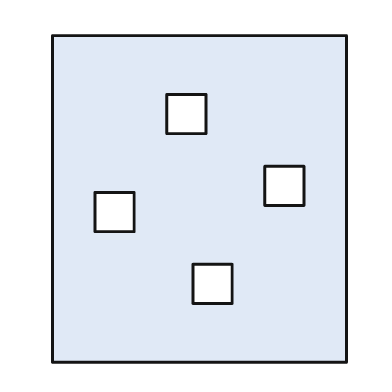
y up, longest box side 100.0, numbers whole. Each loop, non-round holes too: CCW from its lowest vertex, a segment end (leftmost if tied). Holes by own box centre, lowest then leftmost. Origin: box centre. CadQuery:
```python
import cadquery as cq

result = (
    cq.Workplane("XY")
    .moveTo(-45.0, -50.0)
    .lineTo(45.0, -50.0)
    .lineTo(45.0, 50.0)
    .lineTo(-45.0, 50.0)
    .close()
    .moveTo(-2.0, -32.0)
    .lineTo(10.0, -32.0)
    .lineTo(10.0, -20.0)
    .lineTo(-2.0, -20.0)
    .close()
    .moveTo(-32.0, -10.0)
    .lineTo(-20.0, -10.0)
    .lineTo(-20.0, 2.0)
    .lineTo(-32.0, 2.0)
    .close()
    .moveTo(20.0, -2.0)
    .lineTo(32.0, -2.0)
    .lineTo(32.0, 10.0)
    .lineTo(20.0, 10.0)
    .close()
    .moveTo(-10.0, 20.0)
    .lineTo(2.0, 20.0)
    .lineTo(2.0, 32.0)
    .lineTo(-10.0, 32.0)
    .close()
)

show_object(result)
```